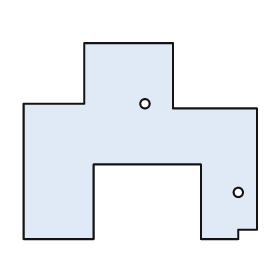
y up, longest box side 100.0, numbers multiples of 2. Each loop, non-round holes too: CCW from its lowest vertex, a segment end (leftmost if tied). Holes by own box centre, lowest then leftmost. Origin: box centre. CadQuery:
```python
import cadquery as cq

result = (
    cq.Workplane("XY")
    .moveTo(-50.0, -42.0)
    .lineTo(-20.0, -42.0)
    .lineTo(-20.0, -10.0)
    .lineTo(26.0, -10.0)
    .lineTo(26.0, -42.0)
    .lineTo(42.0, -42.0)
    .lineTo(42.0, -38.0)
    .lineTo(50.0, -38.0)
    .lineTo(50.0, 14.0)
    .lineTo(14.0, 14.0)
    .lineTo(14.0, 42.0)
    .lineTo(-24.0, 42.0)
    .lineTo(-24.0, 16.0)
    .lineTo(-50.0, 16.0)
    .close()
    .moveTo(42.0, -22.0)
    .circle(2.0)
    .moveTo(2.0, 16.0)
    .circle(2.0)
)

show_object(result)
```